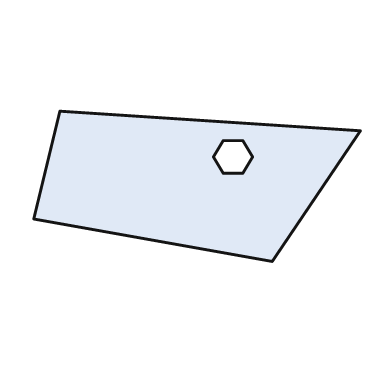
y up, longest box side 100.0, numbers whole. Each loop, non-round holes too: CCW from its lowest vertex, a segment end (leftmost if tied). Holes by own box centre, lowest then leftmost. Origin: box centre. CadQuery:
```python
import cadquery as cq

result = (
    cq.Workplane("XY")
    .moveTo(23.0, -23.0)
    .lineTo(50.0, 17.0)
    .lineTo(-42.0, 23.0)
    .lineTo(-50.0, -10.0)
    .close()
    .moveTo(8.0, 4.0)
    .lineTo(14.0, 4.0)
    .lineTo(17.0, 9.0)
    .lineTo(14.0, 14.0)
    .lineTo(8.0, 14.0)
    .lineTo(5.0, 9.0)
    .close()
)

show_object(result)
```